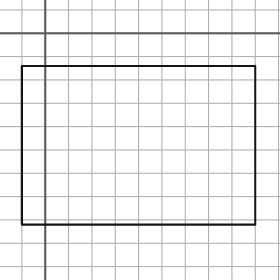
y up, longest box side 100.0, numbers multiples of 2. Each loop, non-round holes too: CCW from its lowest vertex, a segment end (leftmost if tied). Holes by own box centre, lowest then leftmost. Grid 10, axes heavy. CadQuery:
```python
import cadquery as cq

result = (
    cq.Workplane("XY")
    .moveTo(-10.0, -82.0)
    .lineTo(90.0, -82.0)
    .lineTo(90.0, -14.0)
    .lineTo(-10.0, -14.0)
    .close()
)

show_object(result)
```